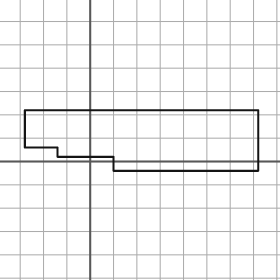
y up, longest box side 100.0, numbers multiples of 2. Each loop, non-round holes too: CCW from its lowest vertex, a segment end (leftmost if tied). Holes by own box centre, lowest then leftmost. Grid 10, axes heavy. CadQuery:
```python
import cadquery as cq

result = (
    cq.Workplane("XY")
    .moveTo(10.0, -4.0)
    .lineTo(72.0, -4.0)
    .lineTo(72.0, 22.0)
    .lineTo(-28.0, 22.0)
    .lineTo(-28.0, 6.0)
    .lineTo(-14.0, 6.0)
    .lineTo(-14.0, 2.0)
    .lineTo(10.0, 2.0)
    .close()
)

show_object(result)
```